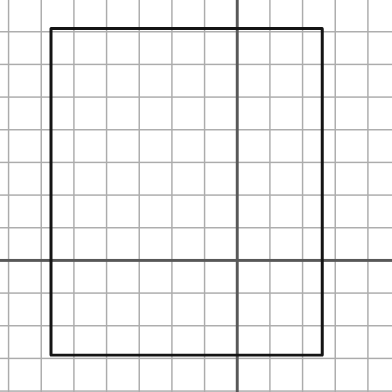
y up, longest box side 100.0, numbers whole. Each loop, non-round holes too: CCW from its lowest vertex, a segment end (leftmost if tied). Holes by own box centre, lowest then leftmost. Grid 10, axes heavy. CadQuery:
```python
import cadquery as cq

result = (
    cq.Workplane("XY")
    .moveTo(-57.0, -29.0)
    .lineTo(26.0, -29.0)
    .lineTo(26.0, 71.0)
    .lineTo(-57.0, 71.0)
    .close()
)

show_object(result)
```